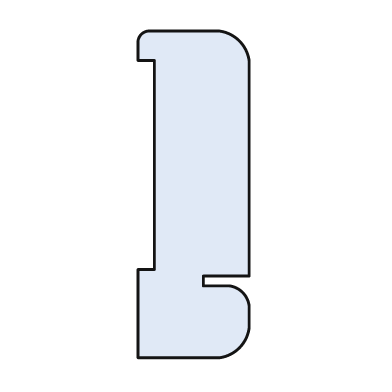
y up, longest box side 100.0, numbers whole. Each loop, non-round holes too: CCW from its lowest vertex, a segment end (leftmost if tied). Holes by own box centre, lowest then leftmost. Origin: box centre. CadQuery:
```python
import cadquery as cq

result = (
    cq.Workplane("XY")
    .moveTo(-17.0, -50.0)
    .lineTo(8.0, -50.0)
    .threePointArc((14.0, -47.0), (17.0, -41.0))
    .lineTo(17.0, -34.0)
    .threePointArc((15.0, -30.0), (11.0, -28.0))
    .lineTo(3.0, -28.0)
    .lineTo(3.0, -25.0)
    .lineTo(17.0, -25.0)
    .lineTo(17.0, 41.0)
    .threePointArc((14.0, 47.0), (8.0, 50.0))
    .lineTo(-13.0, 50.0)
    .threePointArc((-16.0, 49.0), (-17.0, 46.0))
    .lineTo(-17.0, 41.0)
    .lineTo(-12.0, 41.0)
    .lineTo(-12.0, -23.0)
    .lineTo(-17.0, -23.0)
    .close()
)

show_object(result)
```